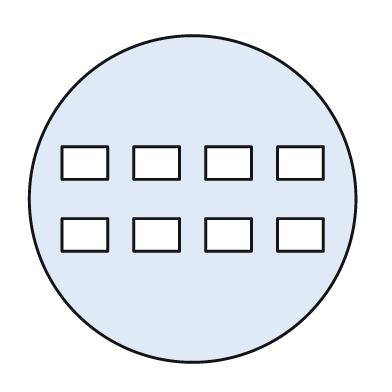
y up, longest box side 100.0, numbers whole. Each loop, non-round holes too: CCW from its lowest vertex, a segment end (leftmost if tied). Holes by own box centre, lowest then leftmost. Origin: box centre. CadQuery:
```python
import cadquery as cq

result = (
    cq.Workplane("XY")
    .moveTo(0.0, 0.0)
    .circle(50.0)
    .moveTo(-40.0, -16.0)
    .lineTo(-26.0, -16.0)
    .lineTo(-26.0, -6.0)
    .lineTo(-40.0, -6.0)
    .close()
    .moveTo(-18.0, -16.0)
    .lineTo(-4.0, -16.0)
    .lineTo(-4.0, -6.0)
    .lineTo(-18.0, -6.0)
    .close()
    .moveTo(4.0, -16.0)
    .lineTo(18.0, -16.0)
    .lineTo(18.0, -6.0)
    .lineTo(4.0, -6.0)
    .close()
    .moveTo(26.0, -16.0)
    .lineTo(40.0, -16.0)
    .lineTo(40.0, -6.0)
    .lineTo(26.0, -6.0)
    .close()
    .moveTo(-40.0, 6.0)
    .lineTo(-26.0, 6.0)
    .lineTo(-26.0, 16.0)
    .lineTo(-40.0, 16.0)
    .close()
    .moveTo(-18.0, 6.0)
    .lineTo(-4.0, 6.0)
    .lineTo(-4.0, 16.0)
    .lineTo(-18.0, 16.0)
    .close()
    .moveTo(4.0, 6.0)
    .lineTo(18.0, 6.0)
    .lineTo(18.0, 16.0)
    .lineTo(4.0, 16.0)
    .close()
    .moveTo(26.0, 6.0)
    .lineTo(40.0, 6.0)
    .lineTo(40.0, 16.0)
    .lineTo(26.0, 16.0)
    .close()
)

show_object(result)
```